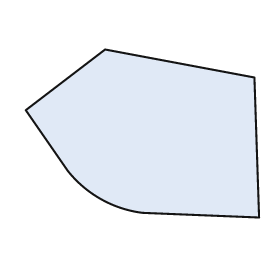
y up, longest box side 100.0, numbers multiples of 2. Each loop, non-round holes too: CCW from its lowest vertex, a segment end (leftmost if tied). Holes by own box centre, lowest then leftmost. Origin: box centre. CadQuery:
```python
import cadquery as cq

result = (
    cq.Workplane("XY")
    .moveTo(50.0, -36.0)
    .lineTo(48.0, 24.0)
    .lineTo(-16.0, 36.0)
    .lineTo(-50.0, 10.0)
    .lineTo(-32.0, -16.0)
    .threePointArc((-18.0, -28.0), (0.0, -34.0))
    .close()
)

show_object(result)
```